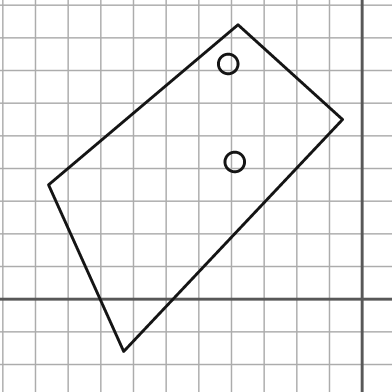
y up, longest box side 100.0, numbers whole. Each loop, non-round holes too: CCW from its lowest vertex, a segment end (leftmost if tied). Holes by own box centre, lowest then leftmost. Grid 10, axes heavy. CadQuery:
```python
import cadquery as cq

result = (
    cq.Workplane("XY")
    .moveTo(-73.0, -16.0)
    .lineTo(-6.0, 55.0)
    .lineTo(-38.0, 84.0)
    .lineTo(-96.0, 35.0)
    .close()
    .moveTo(-39.0, 42.0)
    .circle(3.0)
    .moveTo(-41.0, 72.0)
    .circle(3.0)
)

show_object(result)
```